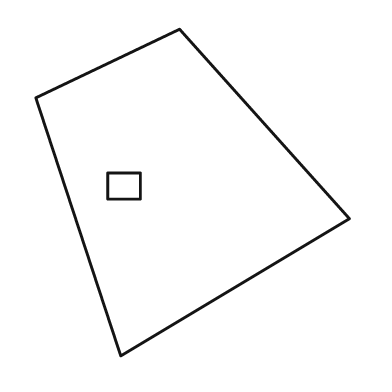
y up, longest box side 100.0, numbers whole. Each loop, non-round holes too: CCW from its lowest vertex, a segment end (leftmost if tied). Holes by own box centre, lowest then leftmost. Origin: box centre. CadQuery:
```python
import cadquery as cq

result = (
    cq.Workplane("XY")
    .moveTo(-22.0, -50.0)
    .lineTo(48.0, -8.0)
    .lineTo(-4.0, 50.0)
    .lineTo(-48.0, 29.0)
    .close()
    .moveTo(-26.0, -2.0)
    .lineTo(-16.0, -2.0)
    .lineTo(-16.0, 6.0)
    .lineTo(-26.0, 6.0)
    .close()
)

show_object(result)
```